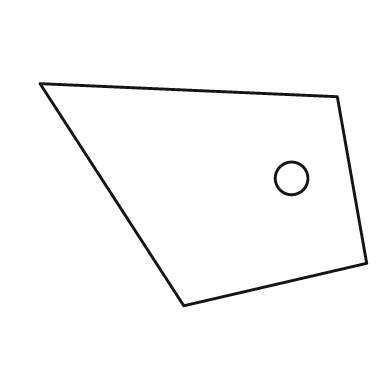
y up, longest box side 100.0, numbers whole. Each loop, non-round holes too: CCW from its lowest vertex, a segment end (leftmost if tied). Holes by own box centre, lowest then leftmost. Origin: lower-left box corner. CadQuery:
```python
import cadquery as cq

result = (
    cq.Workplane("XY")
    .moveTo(44.0, 0.0)
    .lineTo(100.0, 13.0)
    .lineTo(91.0, 64.0)
    .lineTo(0.0, 68.0)
    .close()
    .moveTo(77.0, 39.0)
    .circle(5.0)
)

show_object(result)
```